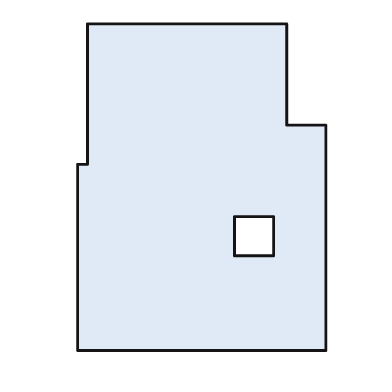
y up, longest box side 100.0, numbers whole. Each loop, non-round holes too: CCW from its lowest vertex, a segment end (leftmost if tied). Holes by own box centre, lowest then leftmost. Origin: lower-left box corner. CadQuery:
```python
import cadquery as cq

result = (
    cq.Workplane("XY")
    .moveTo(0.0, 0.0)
    .lineTo(76.0, 0.0)
    .lineTo(76.0, 69.0)
    .lineTo(64.0, 69.0)
    .lineTo(64.0, 100.0)
    .lineTo(3.0, 100.0)
    .lineTo(3.0, 57.0)
    .lineTo(0.0, 57.0)
    .close()
    .moveTo(48.0, 29.0)
    .lineTo(60.0, 29.0)
    .lineTo(60.0, 41.0)
    .lineTo(48.0, 41.0)
    .close()
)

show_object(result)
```